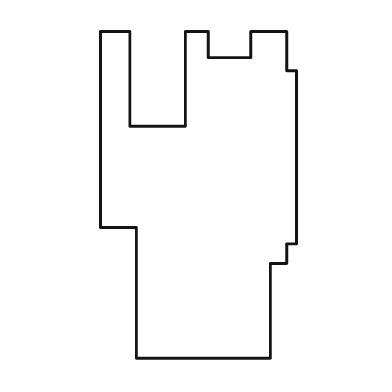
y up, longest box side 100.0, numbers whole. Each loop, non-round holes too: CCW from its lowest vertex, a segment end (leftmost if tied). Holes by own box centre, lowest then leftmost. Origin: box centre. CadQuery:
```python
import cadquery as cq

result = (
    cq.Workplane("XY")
    .moveTo(-19.0, -50.0)
    .lineTo(22.0, -50.0)
    .lineTo(22.0, -21.0)
    .lineTo(27.0, -21.0)
    .lineTo(27.0, -15.0)
    .lineTo(30.0, -15.0)
    .lineTo(30.0, 38.0)
    .lineTo(27.0, 38.0)
    .lineTo(27.0, 50.0)
    .lineTo(16.0, 50.0)
    .lineTo(16.0, 42.0)
    .lineTo(3.0, 42.0)
    .lineTo(3.0, 50.0)
    .lineTo(-4.0, 50.0)
    .lineTo(-4.0, 21.0)
    .lineTo(-21.0, 21.0)
    .lineTo(-21.0, 50.0)
    .lineTo(-30.0, 50.0)
    .lineTo(-30.0, -10.0)
    .lineTo(-19.0, -10.0)
    .close()
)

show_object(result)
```